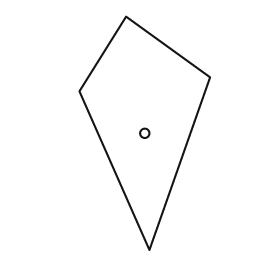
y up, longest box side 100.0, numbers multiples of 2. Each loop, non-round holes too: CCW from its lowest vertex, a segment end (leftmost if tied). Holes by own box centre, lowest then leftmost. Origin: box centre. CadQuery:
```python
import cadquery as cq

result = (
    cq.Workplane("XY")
    .moveTo(2.0, -50.0)
    .lineTo(28.0, 24.0)
    .lineTo(-8.0, 50.0)
    .lineTo(-28.0, 18.0)
    .close()
    .moveTo(0.0, 0.0)
    .circle(2.0)
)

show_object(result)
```